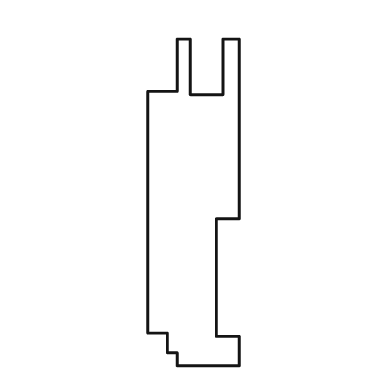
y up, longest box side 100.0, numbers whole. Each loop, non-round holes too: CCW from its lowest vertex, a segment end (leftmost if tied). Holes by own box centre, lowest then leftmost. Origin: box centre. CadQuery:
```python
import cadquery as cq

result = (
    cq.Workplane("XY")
    .moveTo(-5.0, -50.0)
    .lineTo(14.0, -50.0)
    .lineTo(14.0, -41.0)
    .lineTo(7.0, -41.0)
    .lineTo(7.0, -5.0)
    .lineTo(14.0, -5.0)
    .lineTo(14.0, 50.0)
    .lineTo(9.0, 50.0)
    .lineTo(9.0, 33.0)
    .lineTo(-1.0, 33.0)
    .lineTo(-1.0, 50.0)
    .lineTo(-5.0, 50.0)
    .lineTo(-5.0, 34.0)
    .lineTo(-14.0, 34.0)
    .lineTo(-14.0, -40.0)
    .lineTo(-8.0, -40.0)
    .lineTo(-8.0, -46.0)
    .lineTo(-5.0, -46.0)
    .close()
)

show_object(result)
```